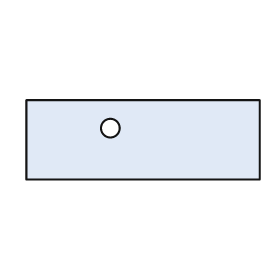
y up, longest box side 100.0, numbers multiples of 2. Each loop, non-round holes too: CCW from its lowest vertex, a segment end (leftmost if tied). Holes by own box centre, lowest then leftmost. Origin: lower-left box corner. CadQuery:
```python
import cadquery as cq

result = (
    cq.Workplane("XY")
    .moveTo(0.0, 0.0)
    .lineTo(100.0, 0.0)
    .lineTo(100.0, 34.0)
    .lineTo(0.0, 34.0)
    .close()
    .moveTo(36.0, 22.0)
    .circle(4.0)
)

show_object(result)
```